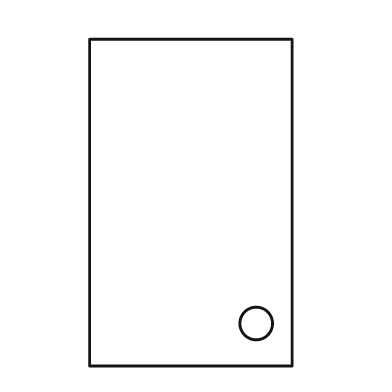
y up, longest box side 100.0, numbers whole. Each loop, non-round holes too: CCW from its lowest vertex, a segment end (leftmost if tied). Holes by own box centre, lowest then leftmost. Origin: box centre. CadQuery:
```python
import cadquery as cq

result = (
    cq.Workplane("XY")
    .moveTo(-31.0, -50.0)
    .lineTo(31.0, -50.0)
    .lineTo(31.0, 50.0)
    .lineTo(-31.0, 50.0)
    .close()
    .moveTo(20.0, -37.0)
    .circle(5.0)
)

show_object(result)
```